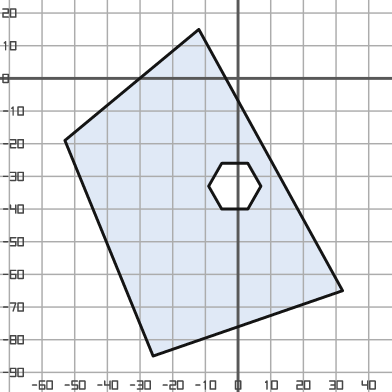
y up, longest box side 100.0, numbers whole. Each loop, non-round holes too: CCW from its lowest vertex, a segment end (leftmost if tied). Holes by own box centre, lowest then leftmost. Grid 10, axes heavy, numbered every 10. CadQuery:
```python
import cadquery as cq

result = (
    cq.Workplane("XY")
    .moveTo(-26.0, -85.0)
    .lineTo(32.0, -65.0)
    .lineTo(-12.0, 15.0)
    .lineTo(-53.0, -19.0)
    .close()
    .moveTo(-5.0, -40.0)
    .lineTo(3.0, -40.0)
    .lineTo(7.0, -33.0)
    .lineTo(3.0, -26.0)
    .lineTo(-5.0, -26.0)
    .lineTo(-9.0, -33.0)
    .close()
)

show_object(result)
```